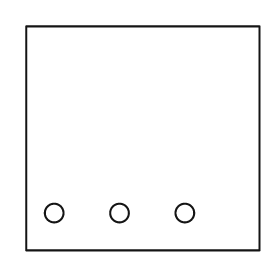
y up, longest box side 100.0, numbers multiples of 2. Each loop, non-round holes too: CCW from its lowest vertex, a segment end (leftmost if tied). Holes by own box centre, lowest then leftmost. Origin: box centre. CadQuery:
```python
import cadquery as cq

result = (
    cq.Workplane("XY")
    .moveTo(-50.0, -48.0)
    .lineTo(50.0, -48.0)
    .lineTo(50.0, 48.0)
    .lineTo(-50.0, 48.0)
    .close()
    .moveTo(-38.0, -32.0)
    .circle(4.0)
    .moveTo(-10.0, -32.0)
    .circle(4.0)
    .moveTo(18.0, -32.0)
    .circle(4.0)
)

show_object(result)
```